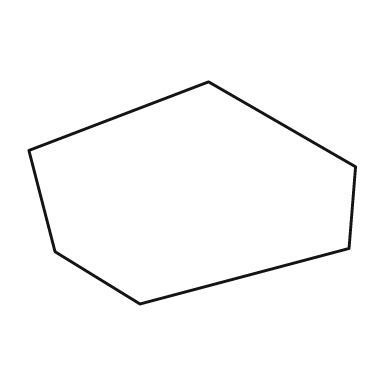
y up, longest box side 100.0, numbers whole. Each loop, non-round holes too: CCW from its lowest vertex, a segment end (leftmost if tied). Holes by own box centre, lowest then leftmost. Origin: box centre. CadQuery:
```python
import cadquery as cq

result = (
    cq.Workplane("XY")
    .moveTo(-16.0, -34.0)
    .lineTo(48.0, -17.0)
    .lineTo(50.0, 8.0)
    .lineTo(5.0, 34.0)
    .lineTo(-50.0, 13.0)
    .lineTo(-42.0, -18.0)
    .close()
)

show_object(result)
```